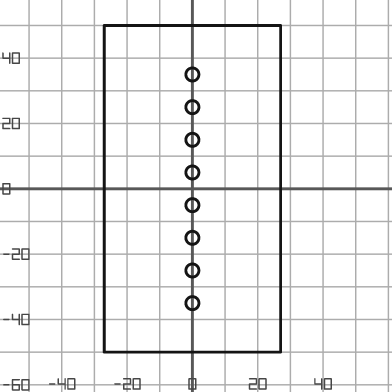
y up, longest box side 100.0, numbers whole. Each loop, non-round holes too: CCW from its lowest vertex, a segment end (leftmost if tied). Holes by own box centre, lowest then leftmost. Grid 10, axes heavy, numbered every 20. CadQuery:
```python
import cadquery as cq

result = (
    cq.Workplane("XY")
    .moveTo(-27.0, -50.0)
    .lineTo(27.0, -50.0)
    .lineTo(27.0, 50.0)
    .lineTo(-27.0, 50.0)
    .close()
    .moveTo(0.0, -35.0)
    .circle(2.0)
    .moveTo(0.0, -25.0)
    .circle(2.0)
    .moveTo(0.0, -15.0)
    .circle(2.0)
    .moveTo(0.0, -5.0)
    .circle(2.0)
    .moveTo(0.0, 5.0)
    .circle(2.0)
    .moveTo(0.0, 15.0)
    .circle(2.0)
    .moveTo(0.0, 25.0)
    .circle(2.0)
    .moveTo(0.0, 35.0)
    .circle(2.0)
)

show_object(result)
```